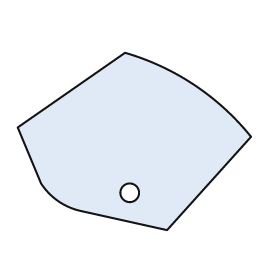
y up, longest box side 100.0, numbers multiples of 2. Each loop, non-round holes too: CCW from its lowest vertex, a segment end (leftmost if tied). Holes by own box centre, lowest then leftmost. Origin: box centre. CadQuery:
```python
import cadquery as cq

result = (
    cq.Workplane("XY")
    .moveTo(14.0, -38.0)
    .lineTo(50.0, 2.0)
    .threePointArc((26.0, 24.0), (-4.0, 38.0))
    .lineTo(-50.0, 6.0)
    .lineTo(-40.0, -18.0)
    .threePointArc((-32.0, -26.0), (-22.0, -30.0))
    .close()
    .moveTo(-2.0, -22.0)
    .circle(4.0)
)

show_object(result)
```